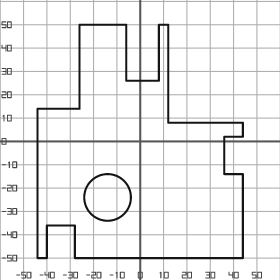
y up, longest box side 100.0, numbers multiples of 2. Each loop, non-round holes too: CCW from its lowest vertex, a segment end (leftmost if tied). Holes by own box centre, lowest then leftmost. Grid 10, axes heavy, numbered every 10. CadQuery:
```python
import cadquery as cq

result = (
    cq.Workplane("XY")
    .moveTo(-44.0, -50.0)
    .lineTo(-40.0, -50.0)
    .lineTo(-40.0, -36.0)
    .lineTo(-28.0, -36.0)
    .lineTo(-28.0, -50.0)
    .lineTo(44.0, -50.0)
    .lineTo(44.0, -14.0)
    .lineTo(36.0, -14.0)
    .lineTo(36.0, 2.0)
    .lineTo(44.0, 2.0)
    .lineTo(44.0, 8.0)
    .lineTo(12.0, 8.0)
    .lineTo(12.0, 50.0)
    .lineTo(8.0, 50.0)
    .lineTo(8.0, 26.0)
    .lineTo(-6.0, 26.0)
    .lineTo(-6.0, 50.0)
    .lineTo(-26.0, 50.0)
    .lineTo(-26.0, 14.0)
    .lineTo(-44.0, 14.0)
    .close()
    .moveTo(-14.0, -24.0)
    .circle(10.0)
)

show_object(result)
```